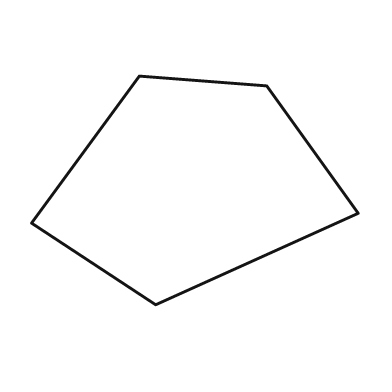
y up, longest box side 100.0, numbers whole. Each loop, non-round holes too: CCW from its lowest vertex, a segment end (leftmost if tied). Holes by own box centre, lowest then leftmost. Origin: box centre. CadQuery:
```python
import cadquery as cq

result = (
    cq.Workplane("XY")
    .moveTo(-12.0, -35.0)
    .lineTo(50.0, -7.0)
    .lineTo(22.0, 32.0)
    .lineTo(-17.0, 35.0)
    .lineTo(-50.0, -10.0)
    .close()
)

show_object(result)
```